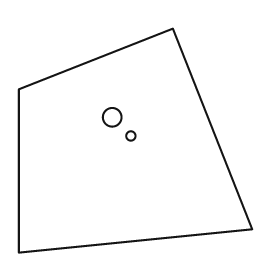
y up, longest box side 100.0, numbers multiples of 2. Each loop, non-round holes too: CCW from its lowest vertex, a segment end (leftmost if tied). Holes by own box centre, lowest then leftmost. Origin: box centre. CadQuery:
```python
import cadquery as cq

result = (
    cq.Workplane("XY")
    .moveTo(-50.0, -48.0)
    .lineTo(50.0, -38.0)
    .lineTo(16.0, 48.0)
    .lineTo(-50.0, 22.0)
    .close()
    .moveTo(-2.0, 2.0)
    .circle(2.0)
    .moveTo(-10.0, 10.0)
    .circle(4.0)
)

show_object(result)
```